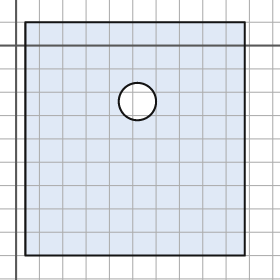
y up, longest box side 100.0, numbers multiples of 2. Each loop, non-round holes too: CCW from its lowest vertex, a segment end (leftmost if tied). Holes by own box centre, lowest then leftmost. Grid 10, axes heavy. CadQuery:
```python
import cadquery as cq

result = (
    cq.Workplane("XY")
    .moveTo(4.0, -90.0)
    .lineTo(98.0, -90.0)
    .lineTo(98.0, 10.0)
    .lineTo(4.0, 10.0)
    .close()
    .moveTo(52.0, -24.0)
    .circle(8.0)
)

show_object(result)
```